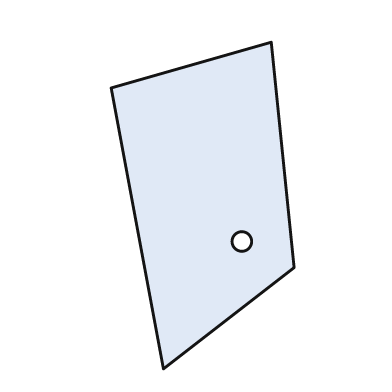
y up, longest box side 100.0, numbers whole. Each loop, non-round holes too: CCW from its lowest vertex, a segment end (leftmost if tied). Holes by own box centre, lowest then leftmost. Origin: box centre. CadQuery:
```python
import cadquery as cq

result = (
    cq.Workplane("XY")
    .moveTo(-12.0, -50.0)
    .lineTo(28.0, -19.0)
    .lineTo(21.0, 50.0)
    .lineTo(-28.0, 36.0)
    .close()
    .moveTo(12.0, -11.0)
    .circle(3.0)
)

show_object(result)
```